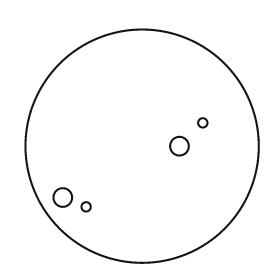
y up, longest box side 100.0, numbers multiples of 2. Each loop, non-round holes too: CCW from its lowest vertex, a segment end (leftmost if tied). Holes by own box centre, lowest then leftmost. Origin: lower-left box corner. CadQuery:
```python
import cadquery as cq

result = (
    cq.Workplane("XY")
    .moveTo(50.0, 50.0)
    .circle(50.0)
    .moveTo(26.0, 24.0)
    .circle(2.0)
    .moveTo(16.0, 28.0)
    .circle(4.0)
    .moveTo(66.0, 50.0)
    .circle(4.0)
    .moveTo(76.0, 60.0)
    .circle(2.0)
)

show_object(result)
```